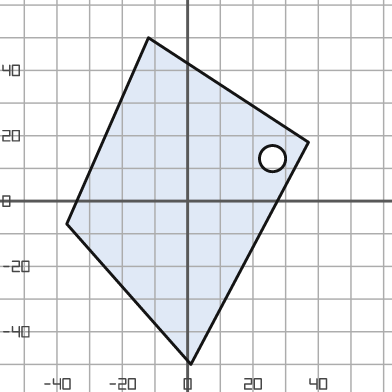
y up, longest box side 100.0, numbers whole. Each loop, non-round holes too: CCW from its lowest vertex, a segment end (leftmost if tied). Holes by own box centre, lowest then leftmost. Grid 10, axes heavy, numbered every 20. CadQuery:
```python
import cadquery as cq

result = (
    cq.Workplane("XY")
    .moveTo(1.0, -50.0)
    .lineTo(37.0, 18.0)
    .lineTo(-12.0, 50.0)
    .lineTo(-37.0, -7.0)
    .close()
    .moveTo(26.0, 13.0)
    .circle(4.0)
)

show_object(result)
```